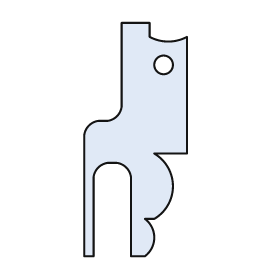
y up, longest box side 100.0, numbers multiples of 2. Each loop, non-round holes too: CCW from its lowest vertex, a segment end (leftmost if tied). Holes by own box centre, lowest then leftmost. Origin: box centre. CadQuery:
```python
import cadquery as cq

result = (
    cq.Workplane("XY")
    .moveTo(-22.0, -50.0)
    .lineTo(-18.0, -50.0)
    .lineTo(-18.0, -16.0)
    .threePointArc((-16.0, -12.0), (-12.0, -10.0))
    .lineTo(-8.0, -10.0)
    .threePointArc((-4.0, -12.0), (-2.0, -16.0))
    .lineTo(-2.0, -50.0)
    .lineTo(4.0, -50.0)
    .threePointArc((8.0, -42.0), (4.0, -34.0))
    .lineTo(8.0, -34.0)
    .threePointArc((16.0, -20.0), (8.0, -6.0))
    .lineTo(22.0, -6.0)
    .lineTo(22.0, 44.0)
    .threePointArc((14.0, 42.0), (6.0, 44.0))
    .lineTo(6.0, 50.0)
    .lineTo(-6.0, 50.0)
    .lineTo(-6.0, 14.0)
    .threePointArc((-8.0, 10.0), (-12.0, 8.0))
    .lineTo(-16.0, 8.0)
    .threePointArc((-20.0, 6.0), (-22.0, 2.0))
    .close()
    .moveTo(12.0, 32.0)
    .circle(4.0)
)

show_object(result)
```